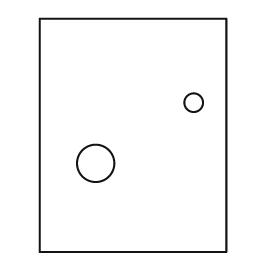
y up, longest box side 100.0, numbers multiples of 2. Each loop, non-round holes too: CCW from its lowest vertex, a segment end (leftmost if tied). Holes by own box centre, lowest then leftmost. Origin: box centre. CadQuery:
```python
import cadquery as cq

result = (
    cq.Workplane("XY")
    .moveTo(-40.0, -50.0)
    .lineTo(40.0, -50.0)
    .lineTo(40.0, 50.0)
    .lineTo(-40.0, 50.0)
    .close()
    .moveTo(-16.0, -12.0)
    .circle(8.0)
    .moveTo(26.0, 14.0)
    .circle(4.0)
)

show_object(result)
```